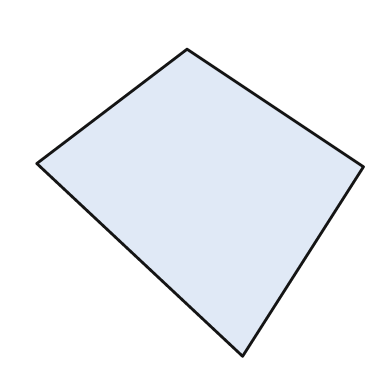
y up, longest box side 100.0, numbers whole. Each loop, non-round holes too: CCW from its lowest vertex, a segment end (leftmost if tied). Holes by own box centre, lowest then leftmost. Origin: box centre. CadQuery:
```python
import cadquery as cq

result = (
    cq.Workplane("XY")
    .moveTo(13.0, -47.0)
    .lineTo(50.0, 11.0)
    .lineTo(-4.0, 47.0)
    .lineTo(-50.0, 12.0)
    .close()
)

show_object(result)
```